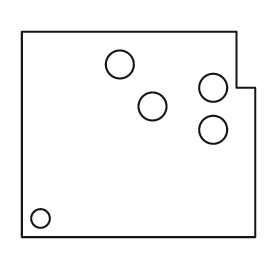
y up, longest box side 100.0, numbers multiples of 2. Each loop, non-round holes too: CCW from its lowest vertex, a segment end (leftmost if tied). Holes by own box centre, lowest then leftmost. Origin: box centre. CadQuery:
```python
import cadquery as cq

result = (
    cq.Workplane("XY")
    .moveTo(-50.0, -44.0)
    .lineTo(50.0, -44.0)
    .lineTo(50.0, 20.0)
    .lineTo(42.0, 20.0)
    .lineTo(42.0, 44.0)
    .lineTo(-50.0, 44.0)
    .close()
    .moveTo(-42.0, -36.0)
    .circle(4.0)
    .moveTo(32.0, 2.0)
    .circle(6.0)
    .moveTo(6.0, 12.0)
    .circle(6.0)
    .moveTo(32.0, 20.0)
    .circle(6.0)
    .moveTo(-8.0, 30.0)
    .circle(6.0)
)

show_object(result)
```